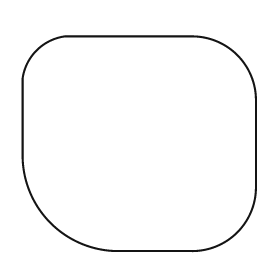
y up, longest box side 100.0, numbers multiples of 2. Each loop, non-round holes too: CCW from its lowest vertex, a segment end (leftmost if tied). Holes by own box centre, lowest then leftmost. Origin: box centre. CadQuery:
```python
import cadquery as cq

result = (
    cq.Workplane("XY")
    .moveTo(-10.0, -46.0)
    .lineTo(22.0, -46.0)
    .threePointArc((42.0, -38.0), (50.0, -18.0))
    .lineTo(50.0, 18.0)
    .threePointArc((42.0, 38.0), (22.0, 46.0))
    .lineTo(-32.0, 46.0)
    .threePointArc((-44.0, 40.0), (-50.0, 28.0))
    .lineTo(-50.0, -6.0)
    .threePointArc((-38.0, -34.0), (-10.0, -46.0))
    .close()
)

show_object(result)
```